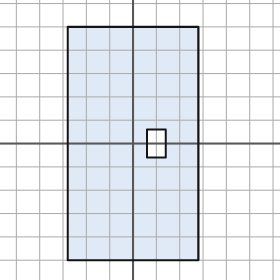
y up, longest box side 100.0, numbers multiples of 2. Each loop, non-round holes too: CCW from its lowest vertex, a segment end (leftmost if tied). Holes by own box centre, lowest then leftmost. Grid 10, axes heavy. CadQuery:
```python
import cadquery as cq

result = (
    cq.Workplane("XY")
    .moveTo(-28.0, -50.0)
    .lineTo(28.0, -50.0)
    .lineTo(28.0, 50.0)
    .lineTo(-28.0, 50.0)
    .close()
    .moveTo(6.0, -6.0)
    .lineTo(14.0, -6.0)
    .lineTo(14.0, 6.0)
    .lineTo(6.0, 6.0)
    .close()
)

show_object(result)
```